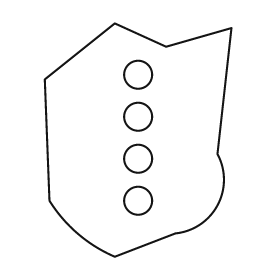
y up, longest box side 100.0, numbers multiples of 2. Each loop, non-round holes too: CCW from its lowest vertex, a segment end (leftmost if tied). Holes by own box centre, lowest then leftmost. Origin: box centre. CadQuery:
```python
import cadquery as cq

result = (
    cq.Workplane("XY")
    .moveTo(-10.0, -50.0)
    .lineTo(16.0, -40.0)
    .threePointArc((34.0, -28.0), (34.0, -6.0))
    .lineTo(40.0, 48.0)
    .lineTo(12.0, 40.0)
    .lineTo(-10.0, 50.0)
    .lineTo(-40.0, 26.0)
    .lineTo(-38.0, -26.0)
    .threePointArc((-26.0, -40.0), (-10.0, -50.0))
    .close()
    .moveTo(0.0, -26.0)
    .circle(6.0)
    .moveTo(0.0, -8.0)
    .circle(6.0)
    .moveTo(0.0, 10.0)
    .circle(6.0)
    .moveTo(0.0, 28.0)
    .circle(6.0)
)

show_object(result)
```